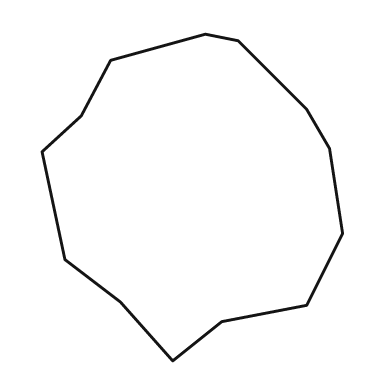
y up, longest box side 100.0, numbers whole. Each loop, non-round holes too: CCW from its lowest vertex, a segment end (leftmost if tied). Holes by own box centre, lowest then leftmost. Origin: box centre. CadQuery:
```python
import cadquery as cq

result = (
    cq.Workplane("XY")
    .moveTo(-6.0, -50.0)
    .lineTo(9.0, -38.0)
    .lineTo(35.0, -33.0)
    .lineTo(46.0, -11.0)
    .lineTo(42.0, 15.0)
    .lineTo(35.0, 27.0)
    .lineTo(14.0, 48.0)
    .lineTo(4.0, 50.0)
    .lineTo(-25.0, 42.0)
    .lineTo(-34.0, 25.0)
    .lineTo(-46.0, 14.0)
    .lineTo(-39.0, -19.0)
    .lineTo(-22.0, -32.0)
    .close()
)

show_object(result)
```